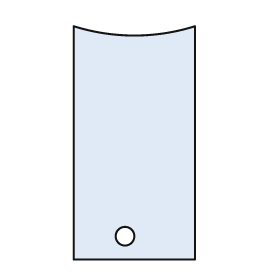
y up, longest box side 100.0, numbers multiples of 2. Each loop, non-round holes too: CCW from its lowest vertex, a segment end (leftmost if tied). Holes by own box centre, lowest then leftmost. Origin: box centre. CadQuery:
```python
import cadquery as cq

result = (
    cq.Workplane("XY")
    .moveTo(-26.0, -50.0)
    .lineTo(26.0, -50.0)
    .lineTo(26.0, 50.0)
    .threePointArc((0.0, 46.0), (-26.0, 50.0))
    .close()
    .moveTo(-4.0, -40.0)
    .circle(4.0)
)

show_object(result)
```